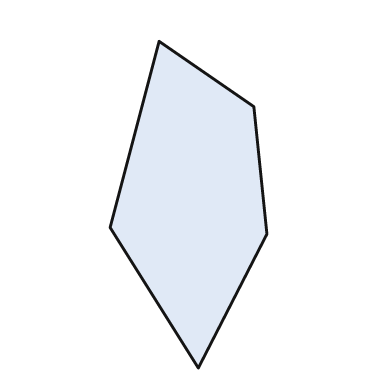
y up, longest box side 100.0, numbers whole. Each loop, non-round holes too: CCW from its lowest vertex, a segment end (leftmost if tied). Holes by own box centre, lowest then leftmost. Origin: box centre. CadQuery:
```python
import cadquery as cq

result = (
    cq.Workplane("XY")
    .moveTo(3.0, -50.0)
    .lineTo(24.0, -9.0)
    .lineTo(20.0, 30.0)
    .lineTo(-9.0, 50.0)
    .lineTo(-24.0, -7.0)
    .close()
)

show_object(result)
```